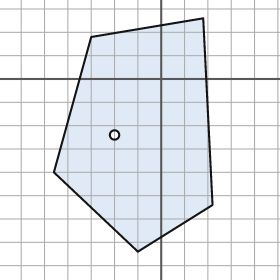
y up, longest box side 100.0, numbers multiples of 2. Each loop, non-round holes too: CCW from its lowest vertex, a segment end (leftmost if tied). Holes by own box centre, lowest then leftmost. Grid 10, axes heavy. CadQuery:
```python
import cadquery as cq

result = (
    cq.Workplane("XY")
    .moveTo(-10.0, -74.0)
    .lineTo(22.0, -54.0)
    .lineTo(18.0, 26.0)
    .lineTo(-30.0, 18.0)
    .lineTo(-46.0, -40.0)
    .close()
    .moveTo(-20.0, -24.0)
    .circle(2.0)
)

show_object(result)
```